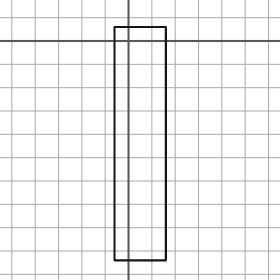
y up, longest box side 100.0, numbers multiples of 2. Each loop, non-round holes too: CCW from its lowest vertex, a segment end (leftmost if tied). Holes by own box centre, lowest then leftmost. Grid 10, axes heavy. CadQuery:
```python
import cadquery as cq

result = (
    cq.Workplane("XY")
    .moveTo(-6.0, -94.0)
    .lineTo(16.0, -94.0)
    .lineTo(16.0, 6.0)
    .lineTo(-6.0, 6.0)
    .close()
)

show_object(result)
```